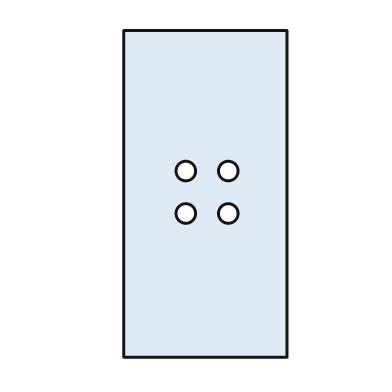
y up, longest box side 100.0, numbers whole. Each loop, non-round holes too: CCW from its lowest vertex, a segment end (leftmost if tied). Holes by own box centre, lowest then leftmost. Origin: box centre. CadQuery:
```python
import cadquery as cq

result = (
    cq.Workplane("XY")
    .moveTo(-25.0, -50.0)
    .lineTo(25.0, -50.0)
    .lineTo(25.0, 50.0)
    .lineTo(-25.0, 50.0)
    .close()
    .moveTo(-6.0, -6.0)
    .circle(3.0)
    .moveTo(7.0, -6.0)
    .circle(3.0)
    .moveTo(-6.0, 7.0)
    .circle(3.0)
    .moveTo(7.0, 7.0)
    .circle(3.0)
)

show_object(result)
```